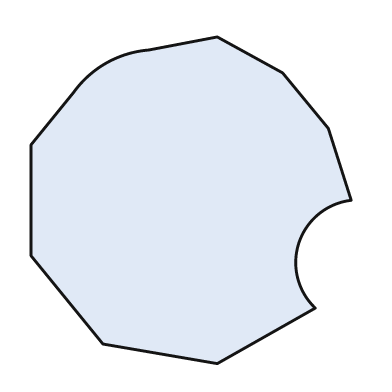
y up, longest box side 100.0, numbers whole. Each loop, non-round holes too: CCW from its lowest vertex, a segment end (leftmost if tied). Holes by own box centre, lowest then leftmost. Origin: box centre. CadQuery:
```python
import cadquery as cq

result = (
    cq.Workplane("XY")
    .moveTo(8.0, -50.0)
    .lineTo(38.0, -33.0)
    .threePointArc((33.0, -13.0), (49.0, 0.0))
    .lineTo(42.0, 22.0)
    .lineTo(28.0, 39.0)
    .lineTo(8.0, 50.0)
    .lineTo(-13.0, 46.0)
    .threePointArc((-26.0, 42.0), (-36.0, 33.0))
    .lineTo(-49.0, 17.0)
    .lineTo(-49.0, -17.0)
    .lineTo(-27.0, -44.0)
    .close()
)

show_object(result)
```